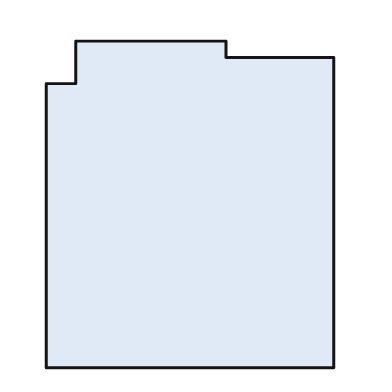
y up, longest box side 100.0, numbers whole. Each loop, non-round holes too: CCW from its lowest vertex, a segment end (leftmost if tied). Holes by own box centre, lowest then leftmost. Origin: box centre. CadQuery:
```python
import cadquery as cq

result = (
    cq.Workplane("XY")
    .moveTo(-44.0, -50.0)
    .lineTo(44.0, -50.0)
    .lineTo(44.0, 45.0)
    .lineTo(11.0, 45.0)
    .lineTo(11.0, 50.0)
    .lineTo(-35.0, 50.0)
    .lineTo(-35.0, 37.0)
    .lineTo(-44.0, 37.0)
    .close()
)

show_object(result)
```